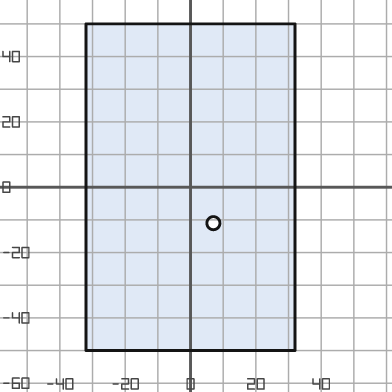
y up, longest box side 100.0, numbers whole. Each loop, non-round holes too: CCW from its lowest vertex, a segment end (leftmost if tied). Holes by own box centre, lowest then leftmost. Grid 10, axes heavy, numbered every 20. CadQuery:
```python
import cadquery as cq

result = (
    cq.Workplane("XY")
    .moveTo(-32.0, -50.0)
    .lineTo(32.0, -50.0)
    .lineTo(32.0, 50.0)
    .lineTo(-32.0, 50.0)
    .close()
    .moveTo(7.0, -11.0)
    .circle(2.0)
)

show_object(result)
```